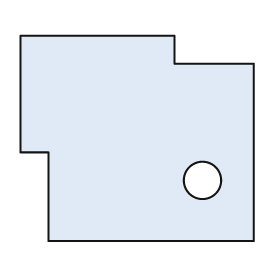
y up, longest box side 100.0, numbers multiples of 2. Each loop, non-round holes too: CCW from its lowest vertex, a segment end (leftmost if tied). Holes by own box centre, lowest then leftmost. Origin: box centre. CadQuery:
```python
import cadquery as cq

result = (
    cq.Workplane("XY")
    .moveTo(-38.0, -44.0)
    .lineTo(50.0, -44.0)
    .lineTo(50.0, 32.0)
    .lineTo(16.0, 32.0)
    .lineTo(16.0, 44.0)
    .lineTo(-50.0, 44.0)
    .lineTo(-50.0, -6.0)
    .lineTo(-38.0, -6.0)
    .close()
    .moveTo(28.0, -18.0)
    .circle(8.0)
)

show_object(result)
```